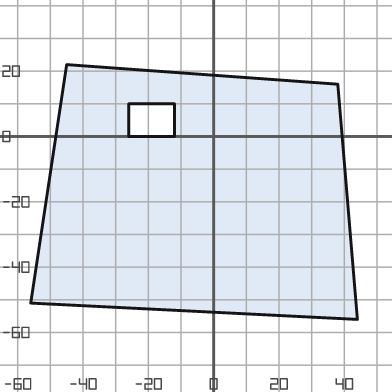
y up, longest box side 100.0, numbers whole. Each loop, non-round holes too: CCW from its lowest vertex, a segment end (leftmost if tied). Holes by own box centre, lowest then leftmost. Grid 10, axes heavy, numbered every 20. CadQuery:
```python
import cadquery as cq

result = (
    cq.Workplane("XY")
    .moveTo(44.0, -56.0)
    .lineTo(38.0, 16.0)
    .lineTo(-45.0, 22.0)
    .lineTo(-56.0, -51.0)
    .close()
    .moveTo(-26.0, 0.0)
    .lineTo(-12.0, 0.0)
    .lineTo(-12.0, 10.0)
    .lineTo(-26.0, 10.0)
    .close()
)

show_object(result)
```